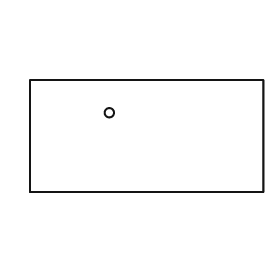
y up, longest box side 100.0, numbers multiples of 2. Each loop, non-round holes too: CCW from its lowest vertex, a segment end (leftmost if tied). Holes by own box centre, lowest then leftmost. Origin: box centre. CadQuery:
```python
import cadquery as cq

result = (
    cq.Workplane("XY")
    .moveTo(-50.0, -24.0)
    .lineTo(50.0, -24.0)
    .lineTo(50.0, 24.0)
    .lineTo(-50.0, 24.0)
    .close()
    .moveTo(-16.0, 10.0)
    .circle(2.0)
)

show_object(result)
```